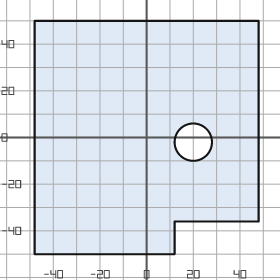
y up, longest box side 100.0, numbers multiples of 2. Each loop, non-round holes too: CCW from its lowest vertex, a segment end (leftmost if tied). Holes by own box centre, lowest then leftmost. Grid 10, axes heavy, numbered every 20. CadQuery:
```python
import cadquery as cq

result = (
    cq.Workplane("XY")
    .moveTo(-48.0, -50.0)
    .lineTo(12.0, -50.0)
    .lineTo(12.0, -36.0)
    .lineTo(48.0, -36.0)
    .lineTo(48.0, 50.0)
    .lineTo(-48.0, 50.0)
    .close()
    .moveTo(20.0, -2.0)
    .circle(8.0)
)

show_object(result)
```